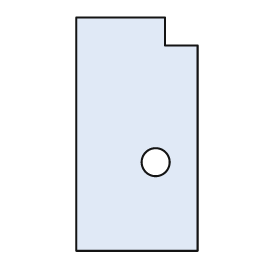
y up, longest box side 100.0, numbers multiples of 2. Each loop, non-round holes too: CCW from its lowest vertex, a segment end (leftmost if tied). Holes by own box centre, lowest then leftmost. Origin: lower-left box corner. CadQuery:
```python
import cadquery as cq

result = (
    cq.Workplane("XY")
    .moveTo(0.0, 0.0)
    .lineTo(52.0, 0.0)
    .lineTo(52.0, 88.0)
    .lineTo(38.0, 88.0)
    .lineTo(38.0, 100.0)
    .lineTo(0.0, 100.0)
    .close()
    .moveTo(34.0, 38.0)
    .circle(6.0)
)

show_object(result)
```